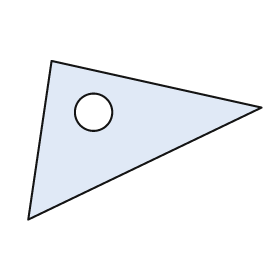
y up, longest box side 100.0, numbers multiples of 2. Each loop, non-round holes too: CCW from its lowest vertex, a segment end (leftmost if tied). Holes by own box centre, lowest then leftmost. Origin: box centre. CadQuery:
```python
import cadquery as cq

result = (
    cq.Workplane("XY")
    .moveTo(-50.0, -34.0)
    .lineTo(50.0, 14.0)
    .lineTo(-40.0, 34.0)
    .close()
    .moveTo(-22.0, 12.0)
    .circle(8.0)
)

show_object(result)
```